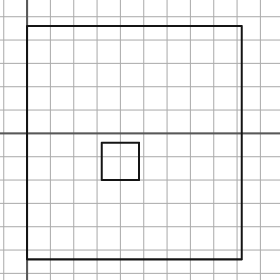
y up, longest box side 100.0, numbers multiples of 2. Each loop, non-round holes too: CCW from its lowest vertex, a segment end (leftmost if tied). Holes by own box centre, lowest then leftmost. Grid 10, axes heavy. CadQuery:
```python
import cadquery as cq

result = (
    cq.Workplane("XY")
    .moveTo(0.0, -54.0)
    .lineTo(92.0, -54.0)
    .lineTo(92.0, 46.0)
    .lineTo(0.0, 46.0)
    .close()
    .moveTo(32.0, -20.0)
    .lineTo(48.0, -20.0)
    .lineTo(48.0, -4.0)
    .lineTo(32.0, -4.0)
    .close()
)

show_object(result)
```